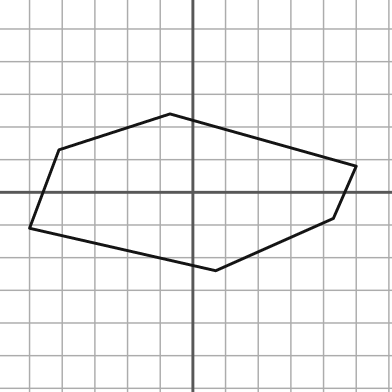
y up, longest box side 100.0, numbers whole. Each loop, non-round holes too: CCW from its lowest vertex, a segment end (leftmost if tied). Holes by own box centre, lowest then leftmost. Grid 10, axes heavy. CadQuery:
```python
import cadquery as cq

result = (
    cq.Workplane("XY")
    .moveTo(7.0, -24.0)
    .lineTo(43.0, -8.0)
    .lineTo(50.0, 8.0)
    .lineTo(-7.0, 24.0)
    .lineTo(-41.0, 13.0)
    .lineTo(-50.0, -11.0)
    .close()
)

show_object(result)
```